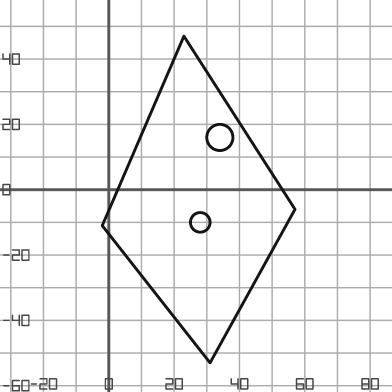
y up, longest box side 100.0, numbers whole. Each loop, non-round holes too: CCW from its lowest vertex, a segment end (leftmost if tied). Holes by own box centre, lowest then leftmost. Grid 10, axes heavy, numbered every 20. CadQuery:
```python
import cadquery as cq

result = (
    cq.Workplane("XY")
    .moveTo(31.0, -53.0)
    .lineTo(57.0, -6.0)
    .lineTo(23.0, 47.0)
    .lineTo(-2.0, -11.0)
    .close()
    .moveTo(28.0, -10.0)
    .circle(3.0)
    .moveTo(34.0, 16.0)
    .circle(4.0)
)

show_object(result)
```